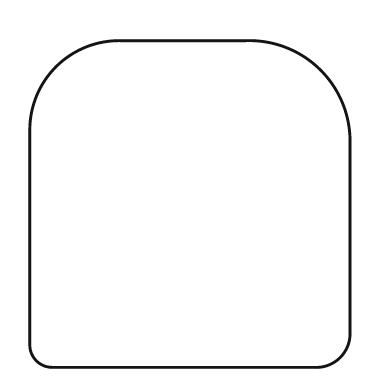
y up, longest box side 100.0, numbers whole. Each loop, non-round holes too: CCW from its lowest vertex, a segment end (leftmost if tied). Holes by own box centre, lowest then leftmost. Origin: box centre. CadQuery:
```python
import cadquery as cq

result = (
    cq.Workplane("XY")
    .moveTo(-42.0, -50.0)
    .lineTo(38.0, -50.0)
    .threePointArc((46.0, -47.0), (49.0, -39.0))
    .lineTo(49.0, 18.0)
    .threePointArc((40.0, 41.0), (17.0, 50.0))
    .lineTo(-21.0, 50.0)
    .threePointArc((-41.0, 42.0), (-49.0, 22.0))
    .lineTo(-49.0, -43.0)
    .threePointArc((-47.0, -48.0), (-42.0, -50.0))
    .close()
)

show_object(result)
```